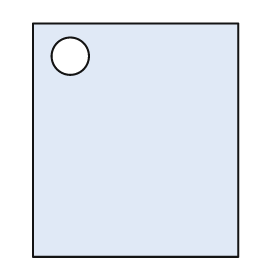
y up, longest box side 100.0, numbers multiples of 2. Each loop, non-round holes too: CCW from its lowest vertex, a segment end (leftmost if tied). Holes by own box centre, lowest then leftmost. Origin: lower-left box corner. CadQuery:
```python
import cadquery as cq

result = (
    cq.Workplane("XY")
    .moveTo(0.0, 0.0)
    .lineTo(88.0, 0.0)
    .lineTo(88.0, 100.0)
    .lineTo(0.0, 100.0)
    .close()
    .moveTo(16.0, 86.0)
    .circle(8.0)
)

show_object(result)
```